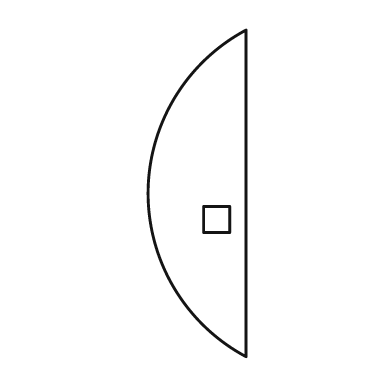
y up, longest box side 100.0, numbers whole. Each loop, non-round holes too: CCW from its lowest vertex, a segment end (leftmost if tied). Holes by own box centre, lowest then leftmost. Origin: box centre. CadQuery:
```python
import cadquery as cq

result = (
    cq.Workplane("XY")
    .moveTo(15.0, -50.0)
    .lineTo(15.0, 50.0)
    .threePointArc((-15.0, 0.0), (15.0, -50.0))
    .close()
    .moveTo(2.0, -12.0)
    .lineTo(10.0, -12.0)
    .lineTo(10.0, -4.0)
    .lineTo(2.0, -4.0)
    .close()
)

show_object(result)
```